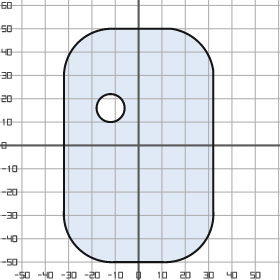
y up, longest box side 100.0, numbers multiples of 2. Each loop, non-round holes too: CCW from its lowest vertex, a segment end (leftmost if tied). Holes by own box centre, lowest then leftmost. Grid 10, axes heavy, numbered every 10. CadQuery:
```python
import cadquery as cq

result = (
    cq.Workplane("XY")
    .moveTo(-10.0, -50.0)
    .lineTo(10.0, -50.0)
    .threePointArc((26.0, -44.0), (32.0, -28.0))
    .lineTo(32.0, 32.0)
    .threePointArc((26.0, 44.0), (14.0, 50.0))
    .lineTo(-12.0, 50.0)
    .threePointArc((-26.0, 44.0), (-32.0, 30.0))
    .lineTo(-32.0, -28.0)
    .threePointArc((-26.0, -44.0), (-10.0, -50.0))
    .close()
    .moveTo(-12.0, 16.0)
    .circle(6.0)
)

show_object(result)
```